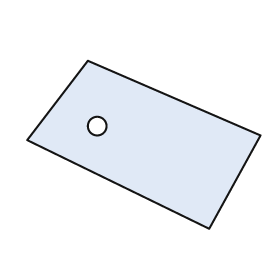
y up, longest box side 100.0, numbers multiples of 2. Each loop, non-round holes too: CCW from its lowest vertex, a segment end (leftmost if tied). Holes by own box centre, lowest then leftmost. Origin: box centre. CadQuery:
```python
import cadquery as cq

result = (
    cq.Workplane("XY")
    .moveTo(28.0, -36.0)
    .lineTo(50.0, 4.0)
    .lineTo(-24.0, 36.0)
    .lineTo(-50.0, 2.0)
    .close()
    .moveTo(-20.0, 8.0)
    .circle(4.0)
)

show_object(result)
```